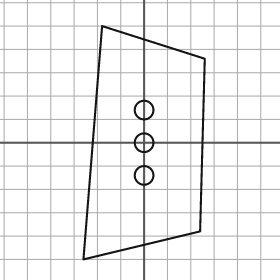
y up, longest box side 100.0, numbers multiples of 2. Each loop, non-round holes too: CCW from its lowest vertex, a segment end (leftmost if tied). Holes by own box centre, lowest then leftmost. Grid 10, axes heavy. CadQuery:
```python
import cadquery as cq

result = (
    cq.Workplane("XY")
    .moveTo(-26.0, -50.0)
    .lineTo(24.0, -38.0)
    .lineTo(26.0, 36.0)
    .lineTo(-18.0, 50.0)
    .close()
    .moveTo(0.0, -14.0)
    .circle(4.0)
    .moveTo(0.0, 0.0)
    .circle(4.0)
    .moveTo(0.0, 14.0)
    .circle(4.0)
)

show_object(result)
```